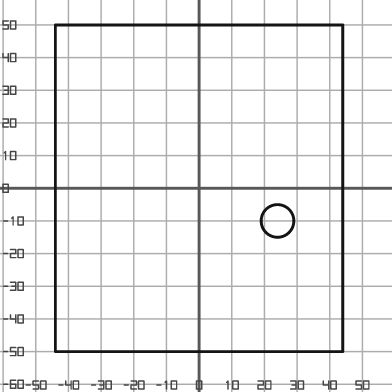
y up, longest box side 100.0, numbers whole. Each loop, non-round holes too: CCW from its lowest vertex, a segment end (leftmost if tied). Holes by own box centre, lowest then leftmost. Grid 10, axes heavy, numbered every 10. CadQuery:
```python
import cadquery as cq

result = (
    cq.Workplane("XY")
    .moveTo(-44.0, -50.0)
    .lineTo(44.0, -50.0)
    .lineTo(44.0, 50.0)
    .lineTo(-44.0, 50.0)
    .close()
    .moveTo(24.0, -10.0)
    .circle(5.0)
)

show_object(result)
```